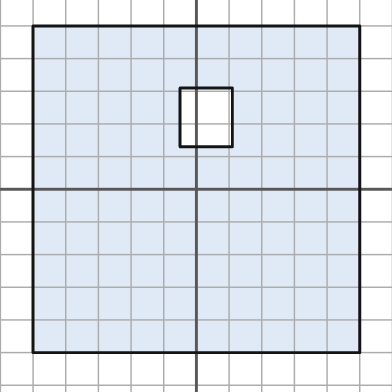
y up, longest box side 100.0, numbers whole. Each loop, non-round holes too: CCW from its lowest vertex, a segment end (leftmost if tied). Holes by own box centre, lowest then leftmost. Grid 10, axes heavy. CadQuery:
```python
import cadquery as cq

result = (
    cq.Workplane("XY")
    .moveTo(-50.0, -50.0)
    .lineTo(50.0, -50.0)
    .lineTo(50.0, 50.0)
    .lineTo(-50.0, 50.0)
    .close()
    .moveTo(-5.0, 13.0)
    .lineTo(11.0, 13.0)
    .lineTo(11.0, 31.0)
    .lineTo(-5.0, 31.0)
    .close()
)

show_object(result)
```